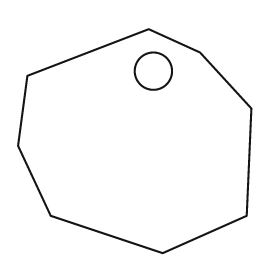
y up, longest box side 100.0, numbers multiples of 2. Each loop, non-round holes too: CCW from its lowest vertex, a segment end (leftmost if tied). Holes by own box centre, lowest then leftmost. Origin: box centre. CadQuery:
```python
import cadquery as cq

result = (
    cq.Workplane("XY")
    .moveTo(12.0, -48.0)
    .lineTo(48.0, -32.0)
    .lineTo(50.0, 14.0)
    .lineTo(28.0, 38.0)
    .lineTo(6.0, 48.0)
    .lineTo(-46.0, 28.0)
    .lineTo(-50.0, -2.0)
    .lineTo(-36.0, -32.0)
    .close()
    .moveTo(8.0, 30.0)
    .circle(8.0)
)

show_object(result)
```